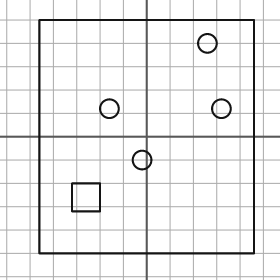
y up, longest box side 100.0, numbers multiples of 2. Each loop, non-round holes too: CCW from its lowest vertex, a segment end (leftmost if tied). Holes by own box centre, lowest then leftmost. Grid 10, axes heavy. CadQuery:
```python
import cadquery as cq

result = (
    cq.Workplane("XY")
    .moveTo(-46.0, -50.0)
    .lineTo(46.0, -50.0)
    .lineTo(46.0, 50.0)
    .lineTo(-46.0, 50.0)
    .close()
    .moveTo(-32.0, -32.0)
    .lineTo(-20.0, -32.0)
    .lineTo(-20.0, -20.0)
    .lineTo(-32.0, -20.0)
    .close()
    .moveTo(-2.0, -10.0)
    .circle(4.0)
    .moveTo(-16.0, 12.0)
    .circle(4.0)
    .moveTo(32.0, 12.0)
    .circle(4.0)
    .moveTo(26.0, 40.0)
    .circle(4.0)
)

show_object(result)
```